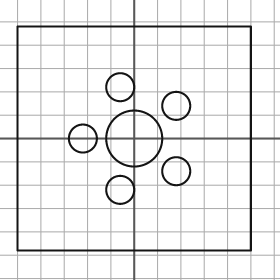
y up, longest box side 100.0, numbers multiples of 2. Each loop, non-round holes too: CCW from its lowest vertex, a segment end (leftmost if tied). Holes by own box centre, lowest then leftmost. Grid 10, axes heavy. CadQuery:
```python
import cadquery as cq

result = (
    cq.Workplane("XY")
    .moveTo(-50.0, -48.0)
    .lineTo(50.0, -48.0)
    .lineTo(50.0, 48.0)
    .lineTo(-50.0, 48.0)
    .close()
    .moveTo(-6.0, -22.0)
    .circle(6.0)
    .moveTo(18.0, -14.0)
    .circle(6.0)
    .moveTo(-22.0, 0.0)
    .circle(6.0)
    .moveTo(0.0, 0.0)
    .circle(12.0)
    .moveTo(18.0, 14.0)
    .circle(6.0)
    .moveTo(-6.0, 22.0)
    .circle(6.0)
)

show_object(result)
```